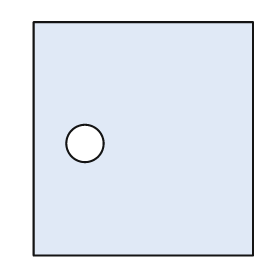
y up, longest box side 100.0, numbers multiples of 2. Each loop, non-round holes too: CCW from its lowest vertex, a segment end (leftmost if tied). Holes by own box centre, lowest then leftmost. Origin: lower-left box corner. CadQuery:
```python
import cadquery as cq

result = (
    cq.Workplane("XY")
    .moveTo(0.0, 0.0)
    .lineTo(94.0, 0.0)
    .lineTo(94.0, 100.0)
    .lineTo(0.0, 100.0)
    .close()
    .moveTo(22.0, 48.0)
    .circle(8.0)
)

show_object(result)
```